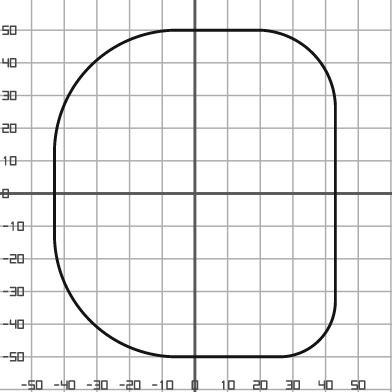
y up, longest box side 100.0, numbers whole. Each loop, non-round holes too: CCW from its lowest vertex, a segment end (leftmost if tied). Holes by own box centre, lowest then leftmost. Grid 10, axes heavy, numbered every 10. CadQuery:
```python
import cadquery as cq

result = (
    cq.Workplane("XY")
    .moveTo(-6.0, -50.0)
    .lineTo(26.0, -50.0)
    .threePointArc((38.0, -45.0), (43.0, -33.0))
    .lineTo(43.0, 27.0)
    .threePointArc((36.0, 43.0), (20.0, 50.0))
    .lineTo(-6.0, 50.0)
    .threePointArc((-32.0, 39.0), (-43.0, 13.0))
    .lineTo(-43.0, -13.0)
    .threePointArc((-32.0, -39.0), (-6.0, -50.0))
    .close()
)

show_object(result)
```